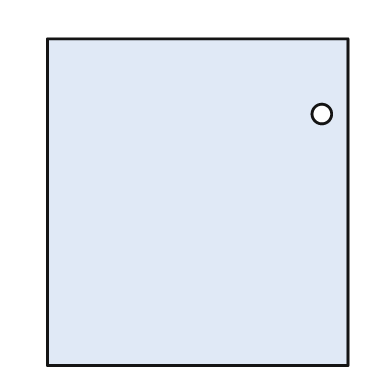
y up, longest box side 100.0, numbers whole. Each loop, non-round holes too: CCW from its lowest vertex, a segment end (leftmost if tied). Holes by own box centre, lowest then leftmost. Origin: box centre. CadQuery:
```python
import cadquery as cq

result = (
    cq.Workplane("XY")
    .moveTo(-46.0, -50.0)
    .lineTo(46.0, -50.0)
    .lineTo(46.0, 50.0)
    .lineTo(-46.0, 50.0)
    .close()
    .moveTo(38.0, 27.0)
    .circle(3.0)
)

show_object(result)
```